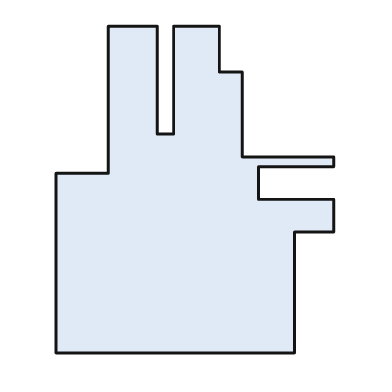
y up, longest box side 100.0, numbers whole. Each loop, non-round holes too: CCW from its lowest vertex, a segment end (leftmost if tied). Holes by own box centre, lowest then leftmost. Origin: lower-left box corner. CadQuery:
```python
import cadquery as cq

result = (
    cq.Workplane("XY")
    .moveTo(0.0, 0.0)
    .lineTo(73.0, 0.0)
    .lineTo(73.0, 37.0)
    .lineTo(85.0, 37.0)
    .lineTo(85.0, 47.0)
    .lineTo(62.0, 47.0)
    .lineTo(62.0, 57.0)
    .lineTo(85.0, 57.0)
    .lineTo(85.0, 60.0)
    .lineTo(57.0, 60.0)
    .lineTo(57.0, 86.0)
    .lineTo(50.0, 86.0)
    .lineTo(50.0, 100.0)
    .lineTo(36.0, 100.0)
    .lineTo(36.0, 67.0)
    .lineTo(31.0, 67.0)
    .lineTo(31.0, 100.0)
    .lineTo(16.0, 100.0)
    .lineTo(16.0, 55.0)
    .lineTo(0.0, 55.0)
    .close()
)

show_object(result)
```